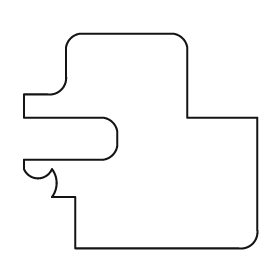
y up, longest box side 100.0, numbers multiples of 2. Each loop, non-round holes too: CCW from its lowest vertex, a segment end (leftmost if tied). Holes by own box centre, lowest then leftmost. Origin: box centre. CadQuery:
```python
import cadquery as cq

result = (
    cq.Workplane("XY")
    .moveTo(-28.0, -46.0)
    .lineTo(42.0, -46.0)
    .threePointArc((48.0, -44.0), (50.0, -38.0))
    .lineTo(50.0, 10.0)
    .lineTo(20.0, 10.0)
    .lineTo(20.0, 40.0)
    .threePointArc((18.0, 44.0), (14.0, 46.0))
    .lineTo(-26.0, 46.0)
    .threePointArc((-30.0, 44.0), (-32.0, 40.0))
    .lineTo(-32.0, 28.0)
    .threePointArc((-34.0, 22.0), (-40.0, 20.0))
    .lineTo(-50.0, 20.0)
    .lineTo(-50.0, 10.0)
    .lineTo(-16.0, 10.0)
    .threePointArc((-12.0, 8.0), (-10.0, 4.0))
    .lineTo(-10.0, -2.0)
    .threePointArc((-12.0, -6.0), (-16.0, -8.0))
    .lineTo(-50.0, -8.0)
    .lineTo(-50.0, -12.0)
    .threePointArc((-44.0, -16.0), (-38.0, -12.0))
    .threePointArc((-36.0, -18.0), (-38.0, -24.0))
    .lineTo(-28.0, -24.0)
    .close()
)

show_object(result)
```